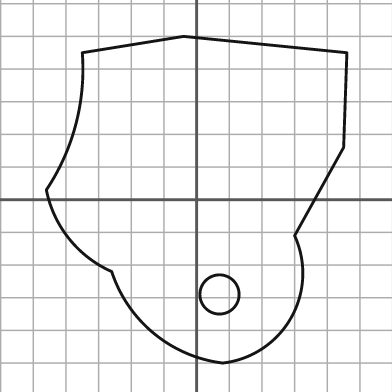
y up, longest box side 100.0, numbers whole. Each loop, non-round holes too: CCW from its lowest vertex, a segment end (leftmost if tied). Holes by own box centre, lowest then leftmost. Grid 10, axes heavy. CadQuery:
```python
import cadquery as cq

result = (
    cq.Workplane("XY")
    .moveTo(8.0, -50.0)
    .threePointArc((29.0, -36.0), (30.0, -11.0))
    .lineTo(45.0, 16.0)
    .lineTo(46.0, 45.0)
    .lineTo(-4.0, 50.0)
    .lineTo(-35.0, 45.0)
    .threePointArc((-37.0, 23.0), (-46.0, 3.0))
    .threePointArc((-39.0, -12.0), (-26.0, -22.0))
    .threePointArc((-13.0, -41.0), (8.0, -50.0))
    .close()
    .moveTo(7.0, -29.0)
    .circle(6.0)
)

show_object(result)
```